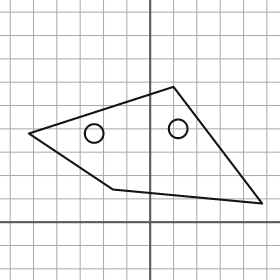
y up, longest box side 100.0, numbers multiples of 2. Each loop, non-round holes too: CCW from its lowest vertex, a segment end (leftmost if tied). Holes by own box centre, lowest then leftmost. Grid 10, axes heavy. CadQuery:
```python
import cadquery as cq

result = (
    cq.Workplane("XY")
    .moveTo(48.0, 8.0)
    .lineTo(10.0, 58.0)
    .lineTo(-52.0, 38.0)
    .lineTo(-16.0, 14.0)
    .close()
    .moveTo(-24.0, 38.0)
    .circle(4.0)
    .moveTo(12.0, 40.0)
    .circle(4.0)
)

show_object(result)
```